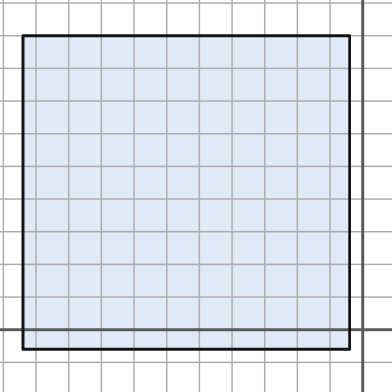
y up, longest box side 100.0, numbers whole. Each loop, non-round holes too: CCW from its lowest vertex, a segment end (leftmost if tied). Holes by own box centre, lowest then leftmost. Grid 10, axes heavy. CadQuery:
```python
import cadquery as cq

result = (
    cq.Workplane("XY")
    .moveTo(-104.0, -6.0)
    .lineTo(-4.0, -6.0)
    .lineTo(-4.0, 90.0)
    .lineTo(-104.0, 90.0)
    .close()
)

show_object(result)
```